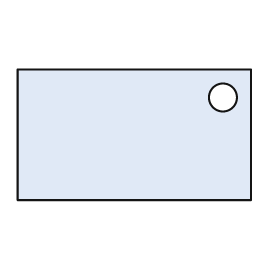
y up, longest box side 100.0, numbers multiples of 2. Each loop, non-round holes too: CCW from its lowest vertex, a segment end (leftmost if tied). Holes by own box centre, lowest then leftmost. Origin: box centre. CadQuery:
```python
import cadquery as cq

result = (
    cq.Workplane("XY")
    .moveTo(-50.0, -28.0)
    .lineTo(50.0, -28.0)
    .lineTo(50.0, 28.0)
    .lineTo(-50.0, 28.0)
    .close()
    .moveTo(38.0, 16.0)
    .circle(6.0)
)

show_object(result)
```